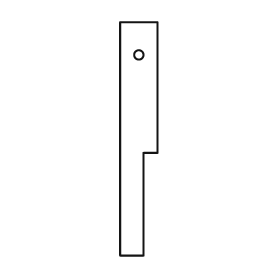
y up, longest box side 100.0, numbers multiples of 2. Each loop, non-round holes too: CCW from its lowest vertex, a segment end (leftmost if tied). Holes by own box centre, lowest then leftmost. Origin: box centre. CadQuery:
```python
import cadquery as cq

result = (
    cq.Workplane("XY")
    .moveTo(-8.0, -50.0)
    .lineTo(2.0, -50.0)
    .lineTo(2.0, -6.0)
    .lineTo(8.0, -6.0)
    .lineTo(8.0, 50.0)
    .lineTo(-8.0, 50.0)
    .close()
    .moveTo(0.0, 36.0)
    .circle(2.0)
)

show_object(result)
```